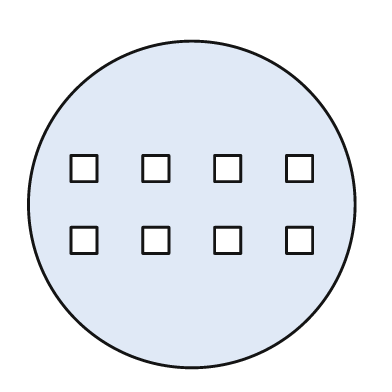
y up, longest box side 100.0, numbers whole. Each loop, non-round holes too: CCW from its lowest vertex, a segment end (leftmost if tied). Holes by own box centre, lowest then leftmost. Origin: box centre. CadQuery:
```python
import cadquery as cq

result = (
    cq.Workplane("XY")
    .moveTo(0.0, 0.0)
    .circle(50.0)
    .moveTo(-37.0, -15.0)
    .lineTo(-29.0, -15.0)
    .lineTo(-29.0, -7.0)
    .lineTo(-37.0, -7.0)
    .close()
    .moveTo(-15.0, -15.0)
    .lineTo(-7.0, -15.0)
    .lineTo(-7.0, -7.0)
    .lineTo(-15.0, -7.0)
    .close()
    .moveTo(7.0, -15.0)
    .lineTo(15.0, -15.0)
    .lineTo(15.0, -7.0)
    .lineTo(7.0, -7.0)
    .close()
    .moveTo(29.0, -15.0)
    .lineTo(37.0, -15.0)
    .lineTo(37.0, -7.0)
    .lineTo(29.0, -7.0)
    .close()
    .moveTo(-37.0, 7.0)
    .lineTo(-29.0, 7.0)
    .lineTo(-29.0, 15.0)
    .lineTo(-37.0, 15.0)
    .close()
    .moveTo(-15.0, 7.0)
    .lineTo(-7.0, 7.0)
    .lineTo(-7.0, 15.0)
    .lineTo(-15.0, 15.0)
    .close()
    .moveTo(7.0, 7.0)
    .lineTo(15.0, 7.0)
    .lineTo(15.0, 15.0)
    .lineTo(7.0, 15.0)
    .close()
    .moveTo(29.0, 7.0)
    .lineTo(37.0, 7.0)
    .lineTo(37.0, 15.0)
    .lineTo(29.0, 15.0)
    .close()
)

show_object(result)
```